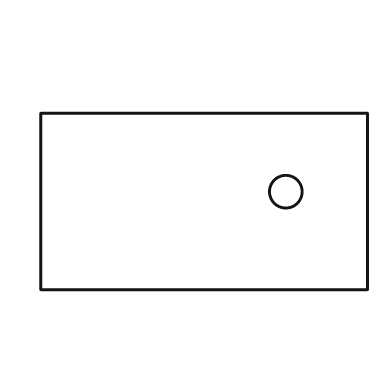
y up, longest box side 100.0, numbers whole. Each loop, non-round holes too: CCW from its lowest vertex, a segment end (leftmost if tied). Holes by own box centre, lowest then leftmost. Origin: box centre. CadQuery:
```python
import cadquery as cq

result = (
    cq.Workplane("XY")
    .moveTo(-50.0, -27.0)
    .lineTo(50.0, -27.0)
    .lineTo(50.0, 27.0)
    .lineTo(-50.0, 27.0)
    .close()
    .moveTo(25.0, 3.0)
    .circle(5.0)
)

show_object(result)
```